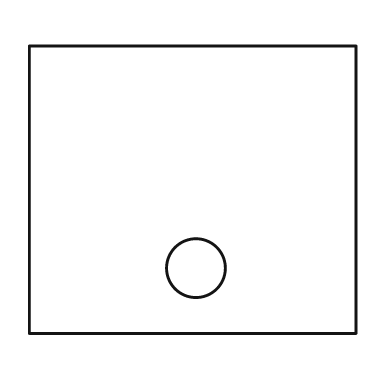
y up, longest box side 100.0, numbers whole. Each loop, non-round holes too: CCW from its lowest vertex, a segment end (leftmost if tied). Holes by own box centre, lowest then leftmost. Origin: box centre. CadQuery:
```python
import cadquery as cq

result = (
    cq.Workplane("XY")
    .moveTo(-50.0, -44.0)
    .lineTo(50.0, -44.0)
    .lineTo(50.0, 44.0)
    .lineTo(-50.0, 44.0)
    .close()
    .moveTo(1.0, -24.0)
    .circle(9.0)
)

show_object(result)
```